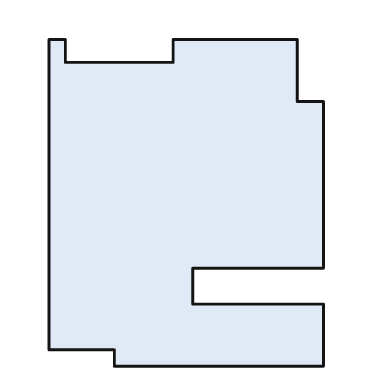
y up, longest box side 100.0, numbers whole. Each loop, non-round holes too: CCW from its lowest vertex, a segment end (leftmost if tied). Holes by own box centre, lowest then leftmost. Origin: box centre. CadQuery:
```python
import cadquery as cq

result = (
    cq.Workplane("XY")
    .moveTo(-22.0, -50.0)
    .lineTo(42.0, -50.0)
    .lineTo(42.0, -31.0)
    .lineTo(2.0, -31.0)
    .lineTo(2.0, -20.0)
    .lineTo(42.0, -20.0)
    .lineTo(42.0, 31.0)
    .lineTo(34.0, 31.0)
    .lineTo(34.0, 50.0)
    .lineTo(-4.0, 50.0)
    .lineTo(-4.0, 43.0)
    .lineTo(-37.0, 43.0)
    .lineTo(-37.0, 50.0)
    .lineTo(-42.0, 50.0)
    .lineTo(-42.0, -45.0)
    .lineTo(-22.0, -45.0)
    .close()
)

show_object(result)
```